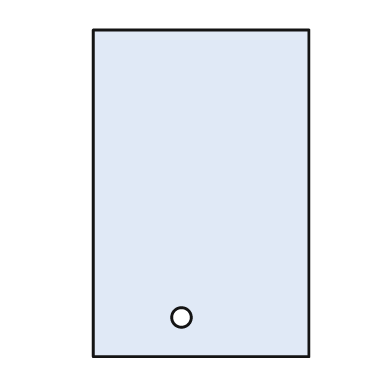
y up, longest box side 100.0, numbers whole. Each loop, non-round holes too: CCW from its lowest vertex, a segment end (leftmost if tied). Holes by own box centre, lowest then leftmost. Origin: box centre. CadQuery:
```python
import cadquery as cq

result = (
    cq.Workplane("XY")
    .moveTo(-33.0, -50.0)
    .lineTo(33.0, -50.0)
    .lineTo(33.0, 50.0)
    .lineTo(-33.0, 50.0)
    .close()
    .moveTo(-6.0, -38.0)
    .circle(3.0)
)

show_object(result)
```